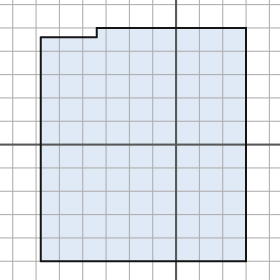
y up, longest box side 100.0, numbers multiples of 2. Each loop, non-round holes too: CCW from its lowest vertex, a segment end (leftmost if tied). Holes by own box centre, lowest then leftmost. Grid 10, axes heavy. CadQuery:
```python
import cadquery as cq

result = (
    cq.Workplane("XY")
    .moveTo(-58.0, -50.0)
    .lineTo(30.0, -50.0)
    .lineTo(30.0, 50.0)
    .lineTo(-34.0, 50.0)
    .lineTo(-34.0, 46.0)
    .lineTo(-58.0, 46.0)
    .close()
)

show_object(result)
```